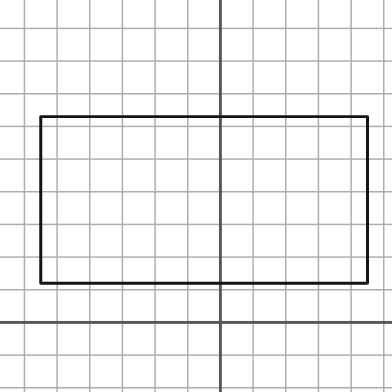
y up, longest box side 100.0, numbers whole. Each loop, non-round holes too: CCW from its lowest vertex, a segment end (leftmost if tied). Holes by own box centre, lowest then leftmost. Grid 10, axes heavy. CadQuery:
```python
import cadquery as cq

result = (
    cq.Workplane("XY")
    .moveTo(-55.0, 12.0)
    .lineTo(45.0, 12.0)
    .lineTo(45.0, 63.0)
    .lineTo(-55.0, 63.0)
    .close()
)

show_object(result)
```